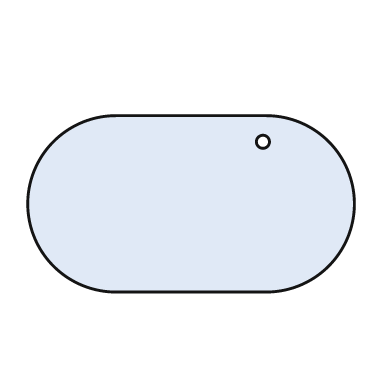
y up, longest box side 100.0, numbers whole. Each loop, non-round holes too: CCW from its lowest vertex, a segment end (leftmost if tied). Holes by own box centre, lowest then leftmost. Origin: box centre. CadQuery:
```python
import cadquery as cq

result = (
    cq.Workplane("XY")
    .moveTo(-23.0, -27.0)
    .lineTo(23.0, -27.0)
    .threePointArc((50.0, 0.0), (23.0, 27.0))
    .lineTo(-23.0, 27.0)
    .threePointArc((-50.0, 0.0), (-23.0, -27.0))
    .close()
    .moveTo(22.0, 19.0)
    .circle(2.0)
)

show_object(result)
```